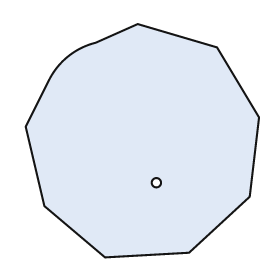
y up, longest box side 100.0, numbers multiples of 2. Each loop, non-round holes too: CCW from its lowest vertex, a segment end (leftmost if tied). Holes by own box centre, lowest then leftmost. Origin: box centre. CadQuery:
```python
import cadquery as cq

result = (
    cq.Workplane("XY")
    .moveTo(-16.0, -50.0)
    .lineTo(20.0, -48.0)
    .lineTo(46.0, -24.0)
    .lineTo(50.0, 10.0)
    .lineTo(32.0, 40.0)
    .lineTo(-2.0, 50.0)
    .lineTo(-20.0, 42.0)
    .threePointArc((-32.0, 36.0), (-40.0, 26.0))
    .lineTo(-50.0, 6.0)
    .lineTo(-42.0, -28.0)
    .close()
    .moveTo(6.0, -18.0)
    .circle(2.0)
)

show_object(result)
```